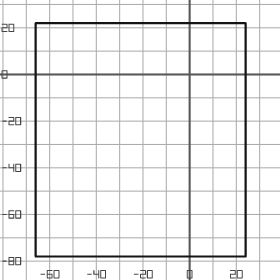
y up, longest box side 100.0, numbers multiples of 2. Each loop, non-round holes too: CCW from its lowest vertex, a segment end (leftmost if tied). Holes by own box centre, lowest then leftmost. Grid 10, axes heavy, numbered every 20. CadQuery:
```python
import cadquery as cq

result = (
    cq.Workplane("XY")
    .moveTo(-66.0, -78.0)
    .lineTo(24.0, -78.0)
    .lineTo(24.0, 22.0)
    .lineTo(-66.0, 22.0)
    .close()
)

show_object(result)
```